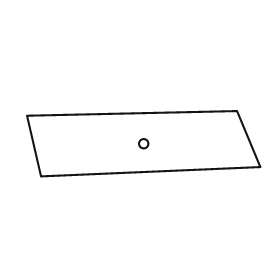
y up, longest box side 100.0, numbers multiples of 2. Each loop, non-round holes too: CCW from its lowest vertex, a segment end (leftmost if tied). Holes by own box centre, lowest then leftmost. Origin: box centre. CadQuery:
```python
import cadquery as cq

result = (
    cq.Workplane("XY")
    .moveTo(-44.0, -14.0)
    .lineTo(50.0, -10.0)
    .lineTo(40.0, 14.0)
    .lineTo(-50.0, 12.0)
    .close()
    .moveTo(0.0, 0.0)
    .circle(2.0)
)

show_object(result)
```